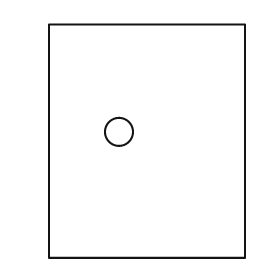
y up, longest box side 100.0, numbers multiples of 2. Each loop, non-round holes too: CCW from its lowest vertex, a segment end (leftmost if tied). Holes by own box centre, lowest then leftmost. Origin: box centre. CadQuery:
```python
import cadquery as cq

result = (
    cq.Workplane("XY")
    .moveTo(-42.0, -50.0)
    .lineTo(42.0, -50.0)
    .lineTo(42.0, 50.0)
    .lineTo(-42.0, 50.0)
    .close()
    .moveTo(-12.0, 4.0)
    .circle(6.0)
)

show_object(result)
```